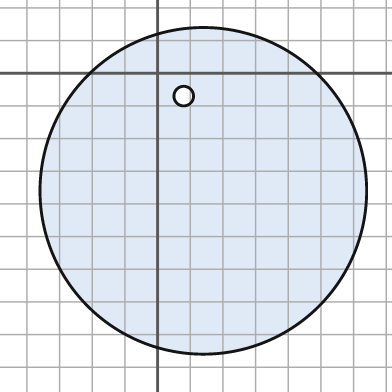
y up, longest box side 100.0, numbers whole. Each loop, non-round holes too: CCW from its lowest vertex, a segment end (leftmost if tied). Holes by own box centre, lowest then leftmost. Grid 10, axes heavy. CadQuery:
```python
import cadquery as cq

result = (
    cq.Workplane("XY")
    .moveTo(14.0, -36.0)
    .circle(50.0)
    .moveTo(8.0, -7.0)
    .circle(3.0)
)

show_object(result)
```